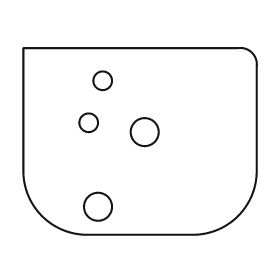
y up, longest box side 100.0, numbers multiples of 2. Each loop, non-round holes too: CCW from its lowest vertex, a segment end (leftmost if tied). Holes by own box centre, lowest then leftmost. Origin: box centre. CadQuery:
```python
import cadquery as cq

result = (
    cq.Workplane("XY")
    .moveTo(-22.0, -40.0)
    .lineTo(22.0, -40.0)
    .threePointArc((42.0, -32.0), (50.0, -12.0))
    .lineTo(50.0, 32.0)
    .threePointArc((48.0, 38.0), (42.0, 40.0))
    .lineTo(-50.0, 40.0)
    .lineTo(-50.0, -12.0)
    .threePointArc((-42.0, -32.0), (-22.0, -40.0))
    .close()
    .moveTo(-18.0, -28.0)
    .circle(6.0)
    .moveTo(2.0, 4.0)
    .circle(6.0)
    .moveTo(-22.0, 8.0)
    .circle(4.0)
    .moveTo(-16.0, 26.0)
    .circle(4.0)
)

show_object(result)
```